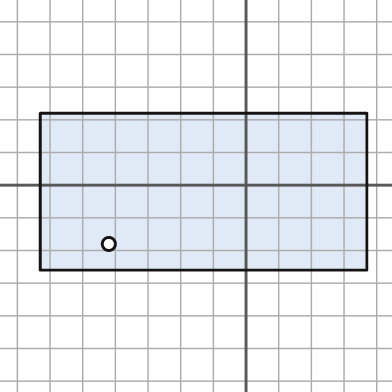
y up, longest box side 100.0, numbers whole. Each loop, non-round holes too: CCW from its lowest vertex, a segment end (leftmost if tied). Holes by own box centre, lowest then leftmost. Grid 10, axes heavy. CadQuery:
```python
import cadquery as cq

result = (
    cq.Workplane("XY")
    .moveTo(-63.0, -26.0)
    .lineTo(37.0, -26.0)
    .lineTo(37.0, 22.0)
    .lineTo(-63.0, 22.0)
    .close()
    .moveTo(-42.0, -18.0)
    .circle(2.0)
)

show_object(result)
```